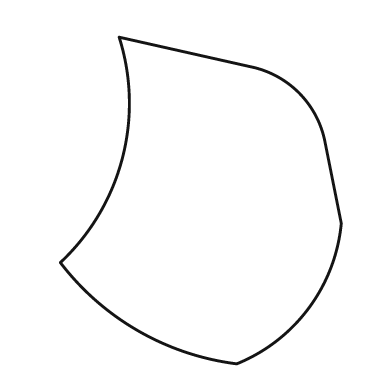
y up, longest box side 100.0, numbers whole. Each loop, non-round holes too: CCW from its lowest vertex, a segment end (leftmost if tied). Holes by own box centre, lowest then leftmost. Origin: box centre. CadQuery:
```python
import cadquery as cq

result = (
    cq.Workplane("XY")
    .moveTo(11.0, -50.0)
    .threePointArc((33.0, -33.0), (43.0, -7.0))
    .lineTo(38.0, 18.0)
    .threePointArc((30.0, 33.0), (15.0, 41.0))
    .lineTo(-25.0, 50.0)
    .threePointArc((-24.0, 13.0), (-43.0, -19.0))
    .threePointArc((-19.0, -40.0), (11.0, -50.0))
    .close()
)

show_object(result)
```